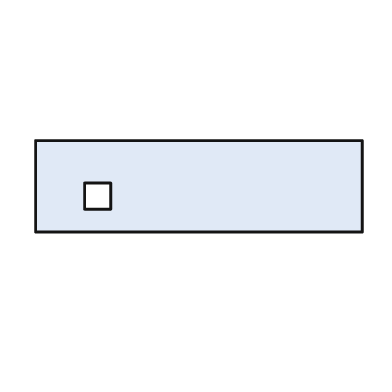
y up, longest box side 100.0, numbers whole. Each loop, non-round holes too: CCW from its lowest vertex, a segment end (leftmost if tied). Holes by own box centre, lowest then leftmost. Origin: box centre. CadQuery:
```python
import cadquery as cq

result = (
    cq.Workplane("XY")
    .moveTo(-50.0, -14.0)
    .lineTo(50.0, -14.0)
    .lineTo(50.0, 14.0)
    .lineTo(-50.0, 14.0)
    .close()
    .moveTo(-35.0, -7.0)
    .lineTo(-27.0, -7.0)
    .lineTo(-27.0, 1.0)
    .lineTo(-35.0, 1.0)
    .close()
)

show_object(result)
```